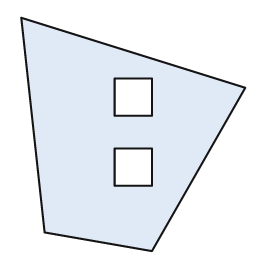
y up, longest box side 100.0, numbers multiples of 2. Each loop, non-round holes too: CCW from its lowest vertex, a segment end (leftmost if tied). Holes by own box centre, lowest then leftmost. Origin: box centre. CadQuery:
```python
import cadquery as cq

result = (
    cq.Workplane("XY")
    .moveTo(8.0, -50.0)
    .lineTo(48.0, 20.0)
    .lineTo(-48.0, 50.0)
    .lineTo(-38.0, -42.0)
    .close()
    .moveTo(-8.0, -22.0)
    .lineTo(8.0, -22.0)
    .lineTo(8.0, -6.0)
    .lineTo(-8.0, -6.0)
    .close()
    .moveTo(-8.0, 8.0)
    .lineTo(8.0, 8.0)
    .lineTo(8.0, 24.0)
    .lineTo(-8.0, 24.0)
    .close()
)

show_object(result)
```